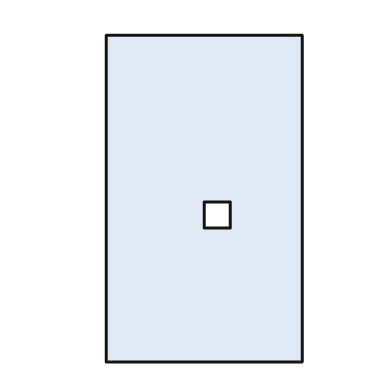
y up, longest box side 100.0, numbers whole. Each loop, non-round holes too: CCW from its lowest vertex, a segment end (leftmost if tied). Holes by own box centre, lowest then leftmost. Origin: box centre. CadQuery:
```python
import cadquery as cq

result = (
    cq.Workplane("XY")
    .moveTo(-30.0, -50.0)
    .lineTo(30.0, -50.0)
    .lineTo(30.0, 50.0)
    .lineTo(-30.0, 50.0)
    .close()
    .moveTo(0.0, -9.0)
    .lineTo(8.0, -9.0)
    .lineTo(8.0, -1.0)
    .lineTo(0.0, -1.0)
    .close()
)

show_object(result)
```